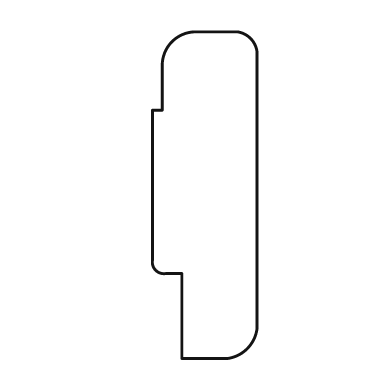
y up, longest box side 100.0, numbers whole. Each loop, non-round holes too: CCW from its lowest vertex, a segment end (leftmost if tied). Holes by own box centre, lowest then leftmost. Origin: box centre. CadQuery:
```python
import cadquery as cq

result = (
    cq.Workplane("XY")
    .moveTo(-7.0, -50.0)
    .lineTo(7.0, -50.0)
    .threePointArc((13.0, -47.0), (16.0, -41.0))
    .lineTo(16.0, 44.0)
    .threePointArc((14.0, 48.0), (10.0, 50.0))
    .lineTo(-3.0, 50.0)
    .threePointArc((-10.0, 47.0), (-13.0, 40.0))
    .lineTo(-13.0, 26.0)
    .lineTo(-16.0, 26.0)
    .lineTo(-16.0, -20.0)
    .threePointArc((-15.0, -23.0), (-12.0, -24.0))
    .lineTo(-7.0, -24.0)
    .close()
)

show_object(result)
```